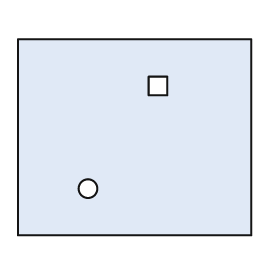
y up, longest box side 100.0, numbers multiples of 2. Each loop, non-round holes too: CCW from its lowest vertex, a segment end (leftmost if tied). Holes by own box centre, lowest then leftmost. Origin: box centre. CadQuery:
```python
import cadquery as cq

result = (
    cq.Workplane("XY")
    .moveTo(-50.0, -42.0)
    .lineTo(50.0, -42.0)
    .lineTo(50.0, 42.0)
    .lineTo(-50.0, 42.0)
    .close()
    .moveTo(-20.0, -22.0)
    .circle(4.0)
    .moveTo(6.0, 18.0)
    .lineTo(14.0, 18.0)
    .lineTo(14.0, 26.0)
    .lineTo(6.0, 26.0)
    .close()
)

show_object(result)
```